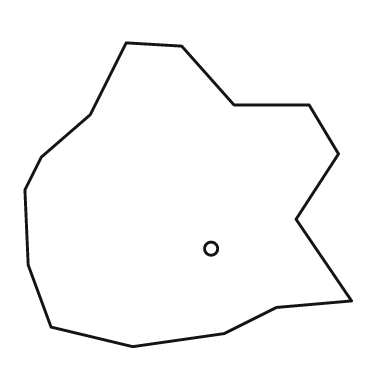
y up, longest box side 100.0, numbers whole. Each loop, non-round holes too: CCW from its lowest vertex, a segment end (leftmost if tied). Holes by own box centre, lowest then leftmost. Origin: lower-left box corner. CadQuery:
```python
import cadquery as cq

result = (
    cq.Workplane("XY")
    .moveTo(33.0, 0.0)
    .lineTo(61.0, 4.0)
    .lineTo(77.0, 12.0)
    .lineTo(100.0, 14.0)
    .lineTo(83.0, 39.0)
    .lineTo(96.0, 59.0)
    .lineTo(87.0, 74.0)
    .lineTo(64.0, 74.0)
    .lineTo(48.0, 92.0)
    .lineTo(31.0, 93.0)
    .lineTo(20.0, 71.0)
    .lineTo(5.0, 58.0)
    .lineTo(0.0, 48.0)
    .lineTo(1.0, 25.0)
    .lineTo(8.0, 6.0)
    .close()
    .moveTo(57.0, 30.0)
    .circle(2.0)
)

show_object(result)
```